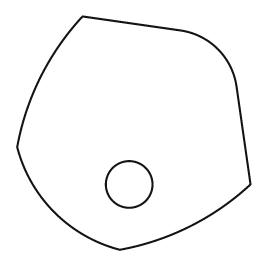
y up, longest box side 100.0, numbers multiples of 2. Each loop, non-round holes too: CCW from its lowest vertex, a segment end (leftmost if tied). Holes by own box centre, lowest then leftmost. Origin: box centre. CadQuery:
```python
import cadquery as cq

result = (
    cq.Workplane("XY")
    .moveTo(-6.0, -50.0)
    .threePointArc((24.0, -40.0), (50.0, -22.0))
    .lineTo(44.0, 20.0)
    .threePointArc((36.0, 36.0), (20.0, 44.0))
    .lineTo(-22.0, 50.0)
    .threePointArc((-40.0, 24.0), (-50.0, -6.0))
    .threePointArc((-34.0, -34.0), (-6.0, -50.0))
    .close()
    .moveTo(-2.0, -22.0)
    .circle(10.0)
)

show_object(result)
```